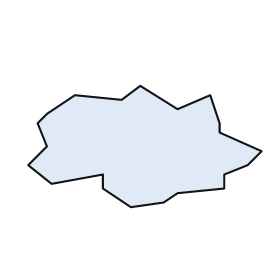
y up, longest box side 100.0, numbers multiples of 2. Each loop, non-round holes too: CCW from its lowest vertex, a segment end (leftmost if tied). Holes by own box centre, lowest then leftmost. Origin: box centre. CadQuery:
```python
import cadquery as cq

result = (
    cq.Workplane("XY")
    .moveTo(-6.0, -26.0)
    .lineTo(8.0, -24.0)
    .lineTo(14.0, -20.0)
    .lineTo(34.0, -18.0)
    .lineTo(34.0, -12.0)
    .lineTo(44.0, -8.0)
    .lineTo(50.0, -2.0)
    .lineTo(32.0, 6.0)
    .lineTo(32.0, 10.0)
    .lineTo(28.0, 22.0)
    .lineTo(14.0, 16.0)
    .lineTo(-2.0, 26.0)
    .lineTo(-10.0, 20.0)
    .lineTo(-30.0, 22.0)
    .lineTo(-42.0, 14.0)
    .lineTo(-46.0, 10.0)
    .lineTo(-42.0, 0.0)
    .lineTo(-50.0, -8.0)
    .lineTo(-40.0, -16.0)
    .lineTo(-18.0, -12.0)
    .lineTo(-18.0, -18.0)
    .close()
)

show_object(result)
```